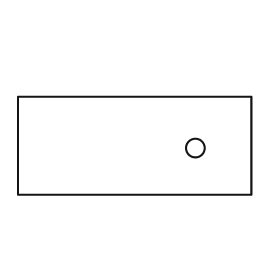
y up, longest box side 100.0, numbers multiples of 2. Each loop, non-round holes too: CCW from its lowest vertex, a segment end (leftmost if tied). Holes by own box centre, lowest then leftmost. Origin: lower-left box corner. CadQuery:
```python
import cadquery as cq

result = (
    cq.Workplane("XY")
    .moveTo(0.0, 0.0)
    .lineTo(100.0, 0.0)
    .lineTo(100.0, 42.0)
    .lineTo(0.0, 42.0)
    .close()
    .moveTo(76.0, 20.0)
    .circle(4.0)
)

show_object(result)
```